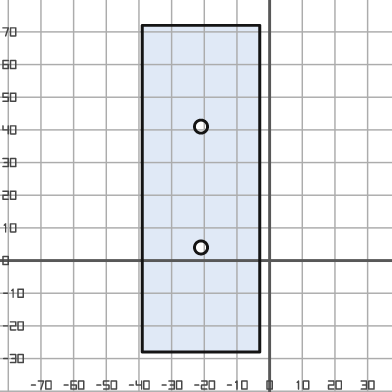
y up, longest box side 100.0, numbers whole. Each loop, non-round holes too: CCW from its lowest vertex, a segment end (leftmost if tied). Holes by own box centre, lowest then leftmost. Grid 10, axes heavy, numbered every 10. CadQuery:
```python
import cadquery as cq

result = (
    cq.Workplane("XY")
    .moveTo(-39.0, -28.0)
    .lineTo(-3.0, -28.0)
    .lineTo(-3.0, 72.0)
    .lineTo(-39.0, 72.0)
    .close()
    .moveTo(-21.0, 4.0)
    .circle(2.0)
    .moveTo(-21.0, 41.0)
    .circle(2.0)
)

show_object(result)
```